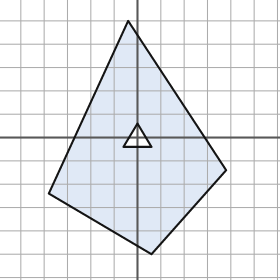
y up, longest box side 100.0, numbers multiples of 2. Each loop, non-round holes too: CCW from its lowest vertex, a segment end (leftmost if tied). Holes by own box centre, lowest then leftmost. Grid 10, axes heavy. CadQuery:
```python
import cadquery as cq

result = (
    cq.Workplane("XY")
    .moveTo(6.0, -50.0)
    .lineTo(38.0, -14.0)
    .lineTo(-4.0, 50.0)
    .lineTo(-38.0, -24.0)
    .close()
    .moveTo(-6.0, -4.0)
    .lineTo(6.0, -4.0)
    .lineTo(0.0, 6.0)
    .close()
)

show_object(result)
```